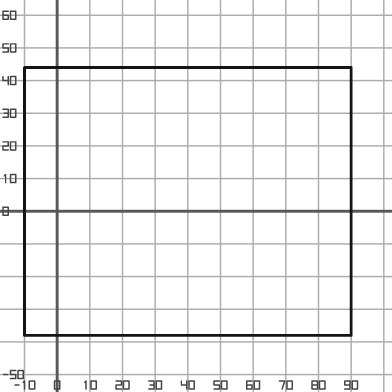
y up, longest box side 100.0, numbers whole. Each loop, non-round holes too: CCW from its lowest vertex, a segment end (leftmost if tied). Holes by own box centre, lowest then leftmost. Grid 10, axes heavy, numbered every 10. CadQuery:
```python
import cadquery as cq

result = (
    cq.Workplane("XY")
    .moveTo(-10.0, -38.0)
    .lineTo(90.0, -38.0)
    .lineTo(90.0, 44.0)
    .lineTo(-10.0, 44.0)
    .close()
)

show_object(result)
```